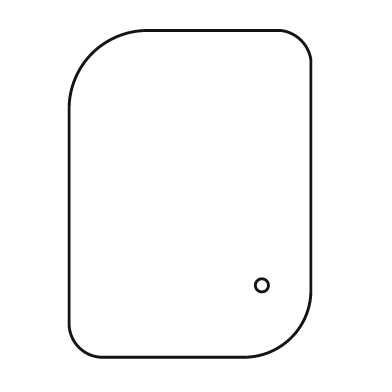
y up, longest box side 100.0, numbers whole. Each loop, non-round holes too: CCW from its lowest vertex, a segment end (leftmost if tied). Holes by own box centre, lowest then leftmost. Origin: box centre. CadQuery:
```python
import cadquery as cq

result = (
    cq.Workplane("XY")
    .moveTo(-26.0, -50.0)
    .lineTo(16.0, -50.0)
    .threePointArc((31.0, -44.0), (37.0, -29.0))
    .lineTo(37.0, 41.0)
    .threePointArc((34.0, 47.0), (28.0, 50.0))
    .lineTo(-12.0, 50.0)
    .threePointArc((-30.0, 43.0), (-37.0, 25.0))
    .lineTo(-37.0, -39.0)
    .threePointArc((-34.0, -47.0), (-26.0, -50.0))
    .close()
    .moveTo(22.0, -28.0)
    .circle(2.0)
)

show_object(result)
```